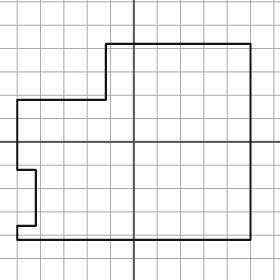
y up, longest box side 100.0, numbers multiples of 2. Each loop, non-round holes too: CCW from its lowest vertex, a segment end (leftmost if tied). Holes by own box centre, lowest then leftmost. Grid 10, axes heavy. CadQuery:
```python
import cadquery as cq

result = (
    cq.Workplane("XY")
    .moveTo(-50.0, -42.0)
    .lineTo(50.0, -42.0)
    .lineTo(50.0, 42.0)
    .lineTo(-12.0, 42.0)
    .lineTo(-12.0, 18.0)
    .lineTo(-50.0, 18.0)
    .lineTo(-50.0, -12.0)
    .lineTo(-42.0, -12.0)
    .lineTo(-42.0, -36.0)
    .lineTo(-50.0, -36.0)
    .close()
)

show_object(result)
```